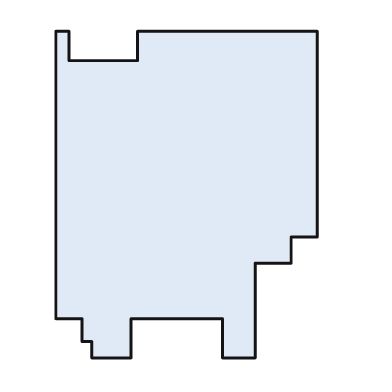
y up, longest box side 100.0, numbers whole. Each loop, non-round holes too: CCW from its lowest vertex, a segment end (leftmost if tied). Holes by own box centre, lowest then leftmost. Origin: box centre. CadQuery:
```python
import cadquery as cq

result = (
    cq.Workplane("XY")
    .moveTo(-29.0, -50.0)
    .lineTo(-17.0, -50.0)
    .lineTo(-17.0, -38.0)
    .lineTo(11.0, -38.0)
    .lineTo(11.0, -50.0)
    .lineTo(21.0, -50.0)
    .lineTo(21.0, -21.0)
    .lineTo(32.0, -21.0)
    .lineTo(32.0, -13.0)
    .lineTo(40.0, -13.0)
    .lineTo(40.0, 50.0)
    .lineTo(-15.0, 50.0)
    .lineTo(-15.0, 41.0)
    .lineTo(-36.0, 41.0)
    .lineTo(-36.0, 50.0)
    .lineTo(-40.0, 50.0)
    .lineTo(-40.0, -38.0)
    .lineTo(-32.0, -38.0)
    .lineTo(-32.0, -45.0)
    .lineTo(-29.0, -45.0)
    .close()
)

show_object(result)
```